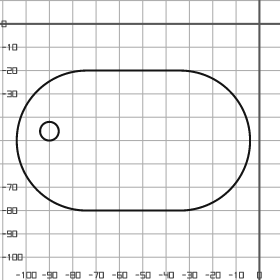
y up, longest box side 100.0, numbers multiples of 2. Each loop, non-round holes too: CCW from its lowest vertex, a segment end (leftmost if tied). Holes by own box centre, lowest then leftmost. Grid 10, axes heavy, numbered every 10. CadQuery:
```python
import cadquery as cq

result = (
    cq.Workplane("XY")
    .moveTo(-74.0, -80.0)
    .lineTo(-34.0, -80.0)
    .threePointArc((-4.0, -50.0), (-34.0, -20.0))
    .lineTo(-74.0, -20.0)
    .threePointArc((-104.0, -50.0), (-74.0, -80.0))
    .close()
    .moveTo(-90.0, -46.0)
    .circle(4.0)
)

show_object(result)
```